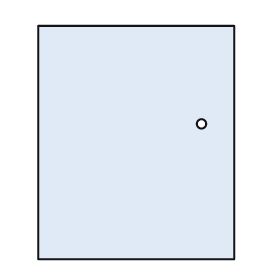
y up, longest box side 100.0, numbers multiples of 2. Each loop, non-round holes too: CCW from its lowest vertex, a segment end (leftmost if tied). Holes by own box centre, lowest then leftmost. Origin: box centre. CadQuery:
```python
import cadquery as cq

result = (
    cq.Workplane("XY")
    .moveTo(-42.0, -50.0)
    .lineTo(42.0, -50.0)
    .lineTo(42.0, 50.0)
    .lineTo(-42.0, 50.0)
    .close()
    .moveTo(28.0, 8.0)
    .circle(2.0)
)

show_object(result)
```